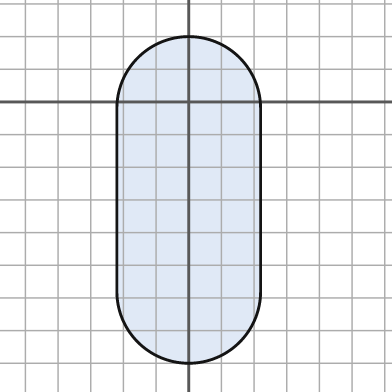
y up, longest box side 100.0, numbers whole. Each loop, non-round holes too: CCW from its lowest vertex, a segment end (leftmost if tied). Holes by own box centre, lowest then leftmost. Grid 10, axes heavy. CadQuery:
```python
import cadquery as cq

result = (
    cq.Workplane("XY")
    .moveTo(-22.0, -58.0)
    .threePointArc((0.0, -80.0), (22.0, -58.0))
    .lineTo(22.0, -2.0)
    .threePointArc((0.0, 20.0), (-22.0, -2.0))
    .close()
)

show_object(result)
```